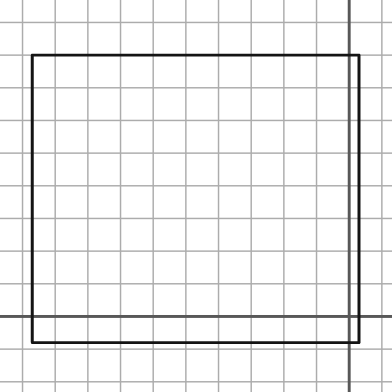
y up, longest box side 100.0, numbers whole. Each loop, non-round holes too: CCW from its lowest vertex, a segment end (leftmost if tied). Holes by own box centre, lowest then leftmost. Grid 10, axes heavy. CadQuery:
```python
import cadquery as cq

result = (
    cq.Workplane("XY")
    .moveTo(-97.0, -8.0)
    .lineTo(3.0, -8.0)
    .lineTo(3.0, 80.0)
    .lineTo(-97.0, 80.0)
    .close()
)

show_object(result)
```